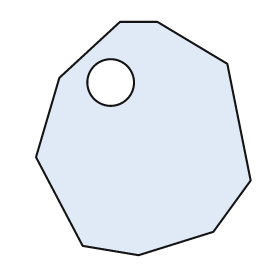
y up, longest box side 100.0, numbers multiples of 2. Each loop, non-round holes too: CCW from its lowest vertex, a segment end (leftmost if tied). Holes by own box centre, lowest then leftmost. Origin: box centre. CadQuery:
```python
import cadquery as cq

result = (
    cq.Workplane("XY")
    .moveTo(-2.0, -50.0)
    .lineTo(30.0, -40.0)
    .lineTo(46.0, -18.0)
    .lineTo(36.0, 32.0)
    .lineTo(6.0, 50.0)
    .lineTo(-10.0, 50.0)
    .lineTo(-36.0, 26.0)
    .lineTo(-46.0, -8.0)
    .lineTo(-26.0, -46.0)
    .close()
    .moveTo(-14.0, 24.0)
    .circle(10.0)
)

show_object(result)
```